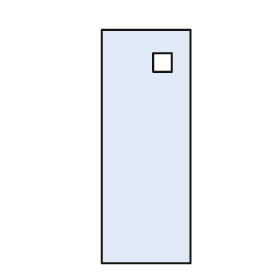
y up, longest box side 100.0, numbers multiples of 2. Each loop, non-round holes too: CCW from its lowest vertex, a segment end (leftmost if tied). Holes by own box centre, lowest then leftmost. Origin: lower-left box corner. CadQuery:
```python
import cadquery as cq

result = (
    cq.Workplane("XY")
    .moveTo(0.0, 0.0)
    .lineTo(38.0, 0.0)
    .lineTo(38.0, 100.0)
    .lineTo(0.0, 100.0)
    .close()
    .moveTo(22.0, 82.0)
    .lineTo(30.0, 82.0)
    .lineTo(30.0, 90.0)
    .lineTo(22.0, 90.0)
    .close()
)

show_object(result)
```